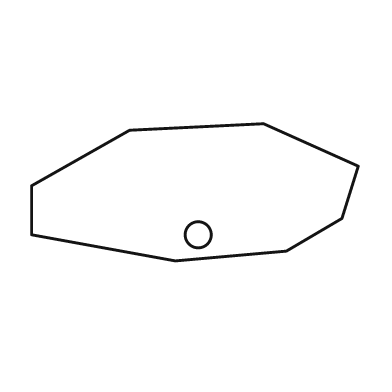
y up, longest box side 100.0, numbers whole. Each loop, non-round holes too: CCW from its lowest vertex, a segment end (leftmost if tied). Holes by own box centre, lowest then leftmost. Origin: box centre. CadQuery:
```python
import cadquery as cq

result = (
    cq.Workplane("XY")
    .moveTo(-6.0, -21.0)
    .lineTo(28.0, -18.0)
    .lineTo(45.0, -8.0)
    .lineTo(50.0, 8.0)
    .lineTo(21.0, 21.0)
    .lineTo(-20.0, 19.0)
    .lineTo(-50.0, 2.0)
    .lineTo(-50.0, -13.0)
    .close()
    .moveTo(1.0, -13.0)
    .circle(4.0)
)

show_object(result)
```